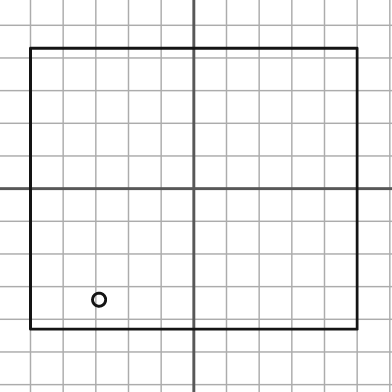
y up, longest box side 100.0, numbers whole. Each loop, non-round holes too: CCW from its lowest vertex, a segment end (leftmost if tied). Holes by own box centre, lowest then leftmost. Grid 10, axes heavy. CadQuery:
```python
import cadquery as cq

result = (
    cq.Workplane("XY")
    .moveTo(-50.0, -43.0)
    .lineTo(50.0, -43.0)
    .lineTo(50.0, 43.0)
    .lineTo(-50.0, 43.0)
    .close()
    .moveTo(-29.0, -34.0)
    .circle(2.0)
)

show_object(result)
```